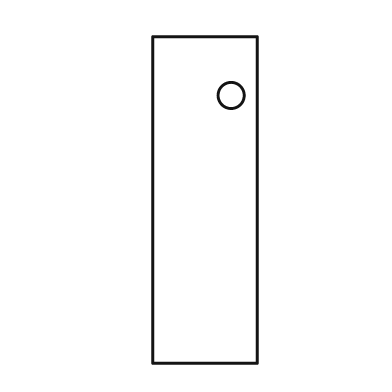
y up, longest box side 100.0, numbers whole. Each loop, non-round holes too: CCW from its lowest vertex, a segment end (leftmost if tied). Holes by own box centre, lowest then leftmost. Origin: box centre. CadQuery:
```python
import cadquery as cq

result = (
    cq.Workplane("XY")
    .moveTo(-16.0, -50.0)
    .lineTo(16.0, -50.0)
    .lineTo(16.0, 50.0)
    .lineTo(-16.0, 50.0)
    .close()
    .moveTo(8.0, 32.0)
    .circle(4.0)
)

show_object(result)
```